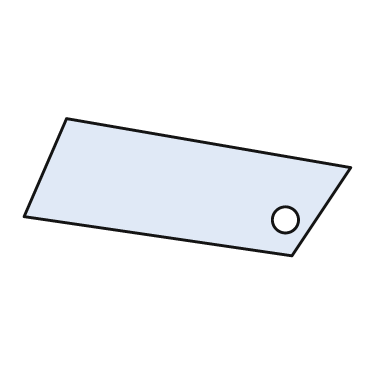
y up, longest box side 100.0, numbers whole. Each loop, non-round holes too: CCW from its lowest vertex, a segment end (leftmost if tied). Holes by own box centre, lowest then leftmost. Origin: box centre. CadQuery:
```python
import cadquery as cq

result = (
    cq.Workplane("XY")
    .moveTo(32.0, -21.0)
    .lineTo(50.0, 6.0)
    .lineTo(-37.0, 21.0)
    .lineTo(-50.0, -9.0)
    .close()
    .moveTo(30.0, -10.0)
    .circle(4.0)
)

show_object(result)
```